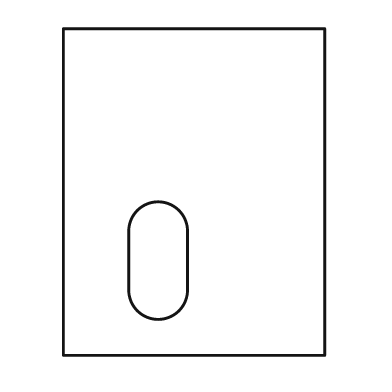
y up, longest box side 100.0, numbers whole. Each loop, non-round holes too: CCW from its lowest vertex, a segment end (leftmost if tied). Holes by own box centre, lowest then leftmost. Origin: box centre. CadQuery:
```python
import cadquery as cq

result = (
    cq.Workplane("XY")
    .moveTo(-40.0, -50.0)
    .lineTo(40.0, -50.0)
    .lineTo(40.0, 50.0)
    .lineTo(-40.0, 50.0)
    .close()
    .moveTo(-20.0, -30.0)
    .threePointArc((-11.0, -39.0), (-2.0, -30.0))
    .lineTo(-2.0, -12.0)
    .threePointArc((-11.0, -3.0), (-20.0, -12.0))
    .close()
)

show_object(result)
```